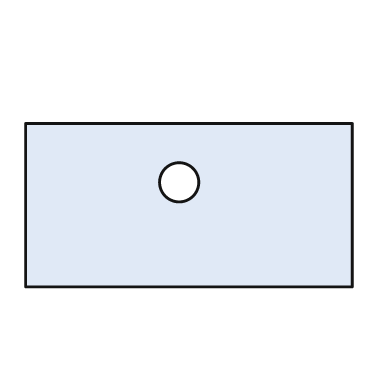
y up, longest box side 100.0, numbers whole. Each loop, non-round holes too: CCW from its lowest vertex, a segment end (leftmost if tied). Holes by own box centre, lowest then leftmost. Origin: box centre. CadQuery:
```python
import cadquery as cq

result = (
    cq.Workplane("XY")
    .moveTo(-50.0, -25.0)
    .lineTo(50.0, -25.0)
    .lineTo(50.0, 25.0)
    .lineTo(-50.0, 25.0)
    .close()
    .moveTo(-3.0, 7.0)
    .circle(6.0)
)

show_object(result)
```